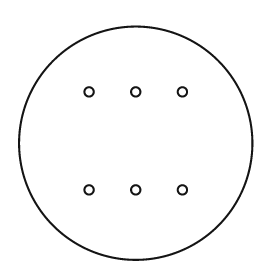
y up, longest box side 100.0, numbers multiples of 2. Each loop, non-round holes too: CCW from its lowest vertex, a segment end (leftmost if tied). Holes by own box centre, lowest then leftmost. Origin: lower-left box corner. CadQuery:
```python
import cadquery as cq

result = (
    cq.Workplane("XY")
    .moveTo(50.0, 50.0)
    .circle(50.0)
    .moveTo(30.0, 30.0)
    .circle(2.0)
    .moveTo(50.0, 30.0)
    .circle(2.0)
    .moveTo(70.0, 30.0)
    .circle(2.0)
    .moveTo(30.0, 72.0)
    .circle(2.0)
    .moveTo(50.0, 72.0)
    .circle(2.0)
    .moveTo(70.0, 72.0)
    .circle(2.0)
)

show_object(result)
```